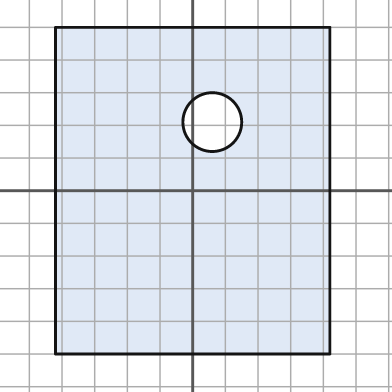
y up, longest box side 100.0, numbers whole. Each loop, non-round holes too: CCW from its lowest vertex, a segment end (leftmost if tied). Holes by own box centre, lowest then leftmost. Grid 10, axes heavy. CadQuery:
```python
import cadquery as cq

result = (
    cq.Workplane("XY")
    .moveTo(-42.0, -50.0)
    .lineTo(42.0, -50.0)
    .lineTo(42.0, 50.0)
    .lineTo(-42.0, 50.0)
    .close()
    .moveTo(6.0, 21.0)
    .circle(9.0)
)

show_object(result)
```